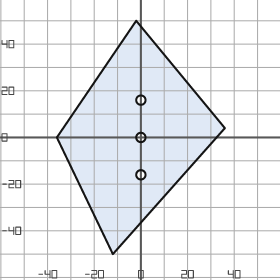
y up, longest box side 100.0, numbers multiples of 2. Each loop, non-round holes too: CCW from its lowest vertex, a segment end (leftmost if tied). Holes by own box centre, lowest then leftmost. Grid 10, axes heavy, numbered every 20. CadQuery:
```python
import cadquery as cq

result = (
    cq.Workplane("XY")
    .moveTo(-12.0, -50.0)
    .lineTo(36.0, 4.0)
    .lineTo(-2.0, 50.0)
    .lineTo(-36.0, 0.0)
    .close()
    .moveTo(0.0, -16.0)
    .circle(2.0)
    .moveTo(0.0, 0.0)
    .circle(2.0)
    .moveTo(0.0, 16.0)
    .circle(2.0)
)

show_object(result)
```